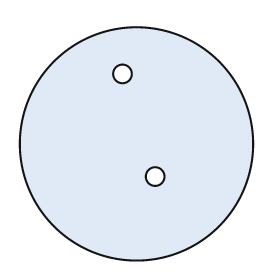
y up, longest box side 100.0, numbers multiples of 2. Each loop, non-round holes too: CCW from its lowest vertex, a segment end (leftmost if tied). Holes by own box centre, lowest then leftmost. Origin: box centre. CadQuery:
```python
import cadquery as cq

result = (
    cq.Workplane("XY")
    .moveTo(0.0, 0.0)
    .circle(50.0)
    .moveTo(8.0, -14.0)
    .circle(4.0)
    .moveTo(-6.0, 30.0)
    .circle(4.0)
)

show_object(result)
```